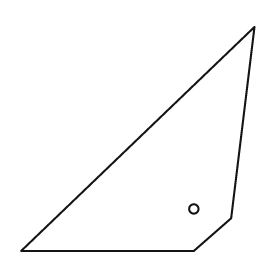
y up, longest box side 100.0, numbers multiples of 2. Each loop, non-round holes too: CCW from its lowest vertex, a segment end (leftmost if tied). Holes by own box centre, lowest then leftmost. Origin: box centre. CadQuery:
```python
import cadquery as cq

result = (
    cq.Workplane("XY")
    .moveTo(-50.0, -48.0)
    .lineTo(24.0, -48.0)
    .lineTo(40.0, -34.0)
    .lineTo(50.0, 48.0)
    .close()
    .moveTo(24.0, -30.0)
    .circle(2.0)
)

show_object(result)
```